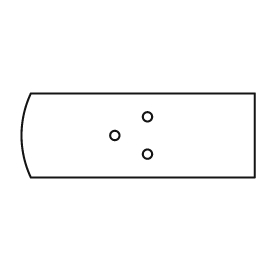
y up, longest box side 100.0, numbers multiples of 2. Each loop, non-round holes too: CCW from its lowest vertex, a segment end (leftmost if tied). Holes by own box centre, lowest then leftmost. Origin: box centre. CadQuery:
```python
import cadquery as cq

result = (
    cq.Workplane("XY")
    .moveTo(-46.0, -18.0)
    .lineTo(50.0, -18.0)
    .lineTo(50.0, 18.0)
    .lineTo(-46.0, 18.0)
    .threePointArc((-50.0, 0.0), (-46.0, -18.0))
    .close()
    .moveTo(4.0, -8.0)
    .circle(2.0)
    .moveTo(-10.0, 0.0)
    .circle(2.0)
    .moveTo(4.0, 8.0)
    .circle(2.0)
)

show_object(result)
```